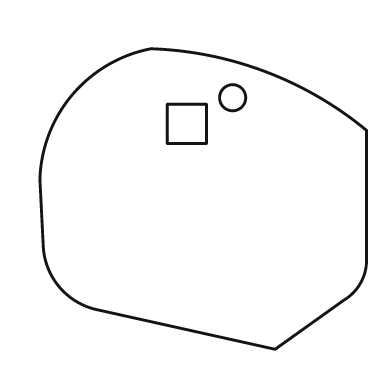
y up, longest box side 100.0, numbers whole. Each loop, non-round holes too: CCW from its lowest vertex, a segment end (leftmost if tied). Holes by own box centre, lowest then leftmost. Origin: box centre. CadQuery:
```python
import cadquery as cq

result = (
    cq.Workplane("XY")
    .moveTo(22.0, -46.0)
    .lineTo(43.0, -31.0)
    .threePointArc((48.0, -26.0), (50.0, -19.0))
    .lineTo(50.0, 21.0)
    .threePointArc((19.0, 39.0), (-16.0, 46.0))
    .threePointArc((-40.0, 32.0), (-50.0, 6.0))
    .lineTo(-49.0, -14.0)
    .threePointArc((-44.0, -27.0), (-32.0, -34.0))
    .close()
    .moveTo(-11.0, 17.0)
    .lineTo(1.0, 17.0)
    .lineTo(1.0, 29.0)
    .lineTo(-11.0, 29.0)
    .close()
    .moveTo(9.0, 31.0)
    .circle(4.0)
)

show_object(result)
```